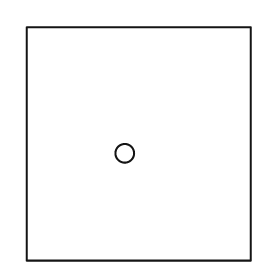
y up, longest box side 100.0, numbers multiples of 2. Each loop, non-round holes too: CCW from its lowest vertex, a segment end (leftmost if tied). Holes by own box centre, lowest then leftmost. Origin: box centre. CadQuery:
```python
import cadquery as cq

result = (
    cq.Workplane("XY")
    .moveTo(-48.0, -50.0)
    .lineTo(48.0, -50.0)
    .lineTo(48.0, 50.0)
    .lineTo(-48.0, 50.0)
    .close()
    .moveTo(-6.0, -4.0)
    .circle(4.0)
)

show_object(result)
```